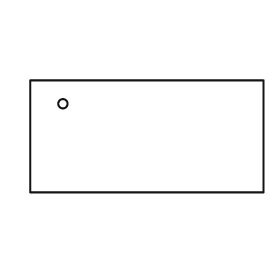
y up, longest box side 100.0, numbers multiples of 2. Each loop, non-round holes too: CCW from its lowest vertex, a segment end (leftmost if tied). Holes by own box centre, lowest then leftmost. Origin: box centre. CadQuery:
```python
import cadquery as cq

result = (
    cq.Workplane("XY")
    .moveTo(-50.0, -24.0)
    .lineTo(50.0, -24.0)
    .lineTo(50.0, 24.0)
    .lineTo(-50.0, 24.0)
    .close()
    .moveTo(-36.0, 14.0)
    .circle(2.0)
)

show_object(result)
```